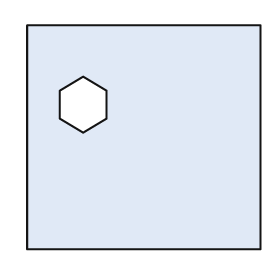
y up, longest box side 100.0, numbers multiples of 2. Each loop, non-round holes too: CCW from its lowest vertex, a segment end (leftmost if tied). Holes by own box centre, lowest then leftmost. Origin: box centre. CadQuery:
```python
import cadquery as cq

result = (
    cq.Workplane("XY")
    .moveTo(-50.0, -48.0)
    .lineTo(50.0, -48.0)
    .lineTo(50.0, 48.0)
    .lineTo(-50.0, 48.0)
    .close()
    .moveTo(-26.0, 2.0)
    .lineTo(-16.0, 8.0)
    .lineTo(-16.0, 20.0)
    .lineTo(-26.0, 26.0)
    .lineTo(-36.0, 20.0)
    .lineTo(-36.0, 8.0)
    .close()
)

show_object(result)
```